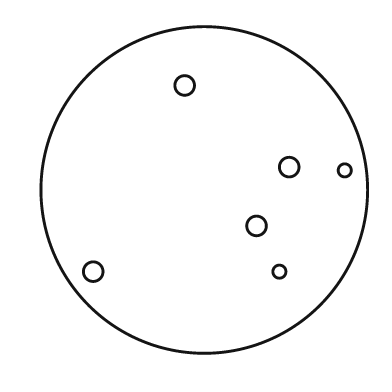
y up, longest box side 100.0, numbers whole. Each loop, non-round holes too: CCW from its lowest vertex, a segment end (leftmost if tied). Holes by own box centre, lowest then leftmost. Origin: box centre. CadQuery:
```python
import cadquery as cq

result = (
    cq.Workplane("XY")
    .moveTo(0.0, 0.0)
    .circle(50.0)
    .moveTo(-34.0, -25.0)
    .circle(3.0)
    .moveTo(23.0, -25.0)
    .circle(2.0)
    .moveTo(16.0, -11.0)
    .circle(3.0)
    .moveTo(43.0, 6.0)
    .circle(2.0)
    .moveTo(26.0, 7.0)
    .circle(3.0)
    .moveTo(-6.0, 32.0)
    .circle(3.0)
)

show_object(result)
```